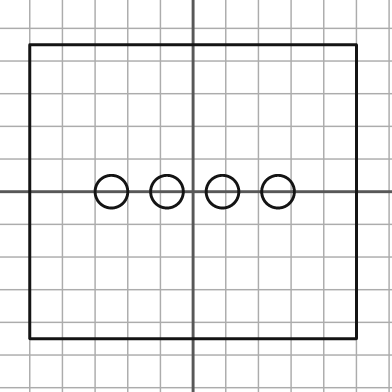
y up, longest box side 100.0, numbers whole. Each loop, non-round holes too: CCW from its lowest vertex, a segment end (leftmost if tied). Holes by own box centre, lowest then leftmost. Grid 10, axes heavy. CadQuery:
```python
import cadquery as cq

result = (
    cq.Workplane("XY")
    .moveTo(-50.0, -45.0)
    .lineTo(50.0, -45.0)
    .lineTo(50.0, 45.0)
    .lineTo(-50.0, 45.0)
    .close()
    .moveTo(-25.0, 0.0)
    .circle(5.0)
    .moveTo(-8.0, 0.0)
    .circle(5.0)
    .moveTo(9.0, 0.0)
    .circle(5.0)
    .moveTo(26.0, 0.0)
    .circle(5.0)
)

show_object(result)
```